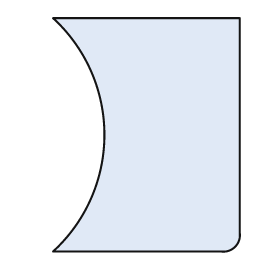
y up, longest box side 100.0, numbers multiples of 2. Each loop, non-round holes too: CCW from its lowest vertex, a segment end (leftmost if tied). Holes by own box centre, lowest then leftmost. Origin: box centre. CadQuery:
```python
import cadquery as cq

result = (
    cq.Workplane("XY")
    .moveTo(-40.0, -50.0)
    .lineTo(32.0, -50.0)
    .threePointArc((38.0, -48.0), (40.0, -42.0))
    .lineTo(40.0, 50.0)
    .lineTo(-40.0, 50.0)
    .threePointArc((-18.0, 0.0), (-40.0, -50.0))
    .close()
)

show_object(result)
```